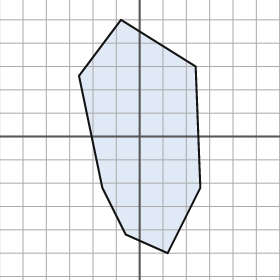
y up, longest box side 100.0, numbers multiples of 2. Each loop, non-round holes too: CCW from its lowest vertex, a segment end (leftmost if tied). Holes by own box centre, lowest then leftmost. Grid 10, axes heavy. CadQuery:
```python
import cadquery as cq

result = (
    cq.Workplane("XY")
    .moveTo(12.0, -50.0)
    .lineTo(26.0, -22.0)
    .lineTo(24.0, 30.0)
    .lineTo(-8.0, 50.0)
    .lineTo(-26.0, 26.0)
    .lineTo(-16.0, -22.0)
    .lineTo(-6.0, -42.0)
    .close()
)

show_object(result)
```